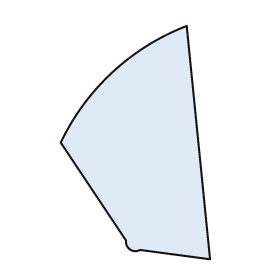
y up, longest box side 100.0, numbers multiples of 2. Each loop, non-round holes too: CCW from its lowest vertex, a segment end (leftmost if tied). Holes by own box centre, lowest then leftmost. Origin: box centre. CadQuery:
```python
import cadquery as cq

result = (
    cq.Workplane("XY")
    .moveTo(32.0, -50.0)
    .lineTo(22.0, 50.0)
    .threePointArc((-10.0, 30.0), (-32.0, 0.0))
    .lineTo(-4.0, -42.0)
    .threePointArc((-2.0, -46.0), (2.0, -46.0))
    .close()
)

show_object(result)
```